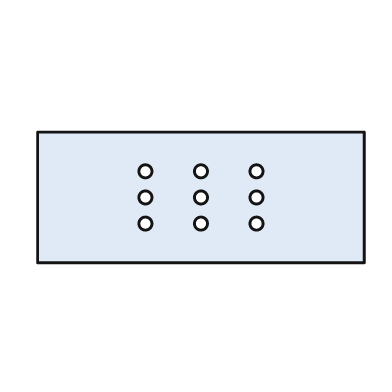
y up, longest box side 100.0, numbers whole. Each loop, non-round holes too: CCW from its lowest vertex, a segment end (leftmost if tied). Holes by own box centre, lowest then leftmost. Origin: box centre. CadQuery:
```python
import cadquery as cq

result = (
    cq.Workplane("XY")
    .moveTo(-50.0, -20.0)
    .lineTo(50.0, -20.0)
    .lineTo(50.0, 20.0)
    .lineTo(-50.0, 20.0)
    .close()
    .moveTo(-17.0, -8.0)
    .circle(2.0)
    .moveTo(0.0, -8.0)
    .circle(2.0)
    .moveTo(17.0, -8.0)
    .circle(2.0)
    .moveTo(-17.0, 0.0)
    .circle(2.0)
    .moveTo(0.0, 0.0)
    .circle(2.0)
    .moveTo(17.0, 0.0)
    .circle(2.0)
    .moveTo(-17.0, 8.0)
    .circle(2.0)
    .moveTo(0.0, 8.0)
    .circle(2.0)
    .moveTo(17.0, 8.0)
    .circle(2.0)
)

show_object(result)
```